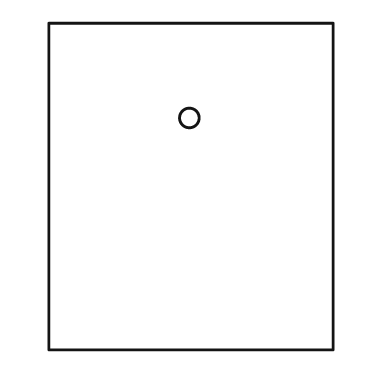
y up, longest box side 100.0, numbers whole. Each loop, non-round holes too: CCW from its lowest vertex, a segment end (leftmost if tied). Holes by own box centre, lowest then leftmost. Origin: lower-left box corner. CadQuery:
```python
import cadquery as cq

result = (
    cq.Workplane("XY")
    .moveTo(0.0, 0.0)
    .lineTo(87.0, 0.0)
    .lineTo(87.0, 100.0)
    .lineTo(0.0, 100.0)
    .close()
    .moveTo(43.0, 71.0)
    .circle(3.0)
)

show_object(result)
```